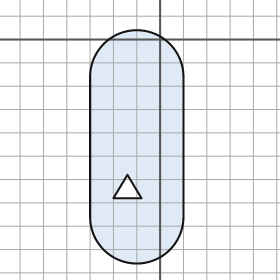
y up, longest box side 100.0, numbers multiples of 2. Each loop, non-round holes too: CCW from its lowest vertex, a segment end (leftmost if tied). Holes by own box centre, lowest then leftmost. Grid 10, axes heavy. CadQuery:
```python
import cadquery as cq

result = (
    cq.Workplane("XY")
    .moveTo(-30.0, -76.0)
    .threePointArc((-10.0, -96.0), (10.0, -76.0))
    .lineTo(10.0, -16.0)
    .threePointArc((-10.0, 4.0), (-30.0, -16.0))
    .close()
    .moveTo(-20.0, -68.0)
    .lineTo(-8.0, -68.0)
    .lineTo(-14.0, -58.0)
    .close()
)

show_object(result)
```